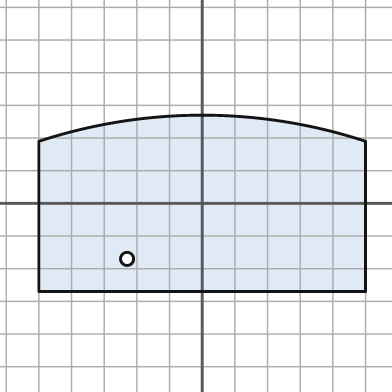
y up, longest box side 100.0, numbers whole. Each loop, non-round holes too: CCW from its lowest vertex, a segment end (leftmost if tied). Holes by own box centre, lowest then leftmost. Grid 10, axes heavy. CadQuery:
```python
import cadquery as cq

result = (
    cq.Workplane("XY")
    .moveTo(-50.0, -27.0)
    .lineTo(50.0, -27.0)
    .lineTo(50.0, 19.0)
    .threePointArc((0.0, 27.0), (-50.0, 19.0))
    .close()
    .moveTo(-23.0, -17.0)
    .circle(2.0)
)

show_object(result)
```